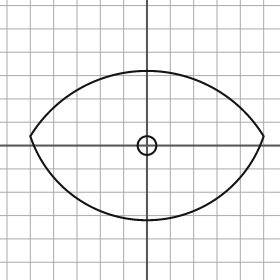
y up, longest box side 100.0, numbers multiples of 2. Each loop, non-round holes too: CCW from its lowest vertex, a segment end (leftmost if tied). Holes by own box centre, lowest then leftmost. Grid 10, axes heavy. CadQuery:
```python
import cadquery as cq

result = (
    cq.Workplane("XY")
    .moveTo(-50.0, 4.0)
    .threePointArc((0.0, -32.0), (50.0, 4.0))
    .threePointArc((0.0, 32.0), (-50.0, 4.0))
    .close()
    .moveTo(0.0, 0.0)
    .circle(4.0)
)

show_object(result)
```